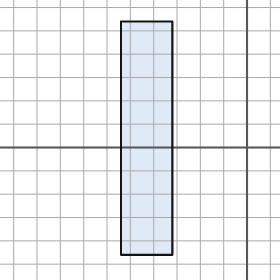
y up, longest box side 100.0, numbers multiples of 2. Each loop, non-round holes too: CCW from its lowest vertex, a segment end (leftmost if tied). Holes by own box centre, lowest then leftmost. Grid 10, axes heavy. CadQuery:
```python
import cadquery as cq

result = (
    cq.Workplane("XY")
    .moveTo(-54.0, -46.0)
    .lineTo(-32.0, -46.0)
    .lineTo(-32.0, 54.0)
    .lineTo(-54.0, 54.0)
    .close()
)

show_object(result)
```